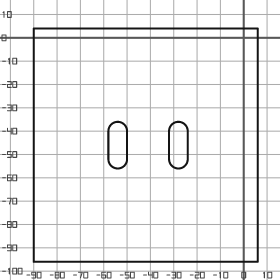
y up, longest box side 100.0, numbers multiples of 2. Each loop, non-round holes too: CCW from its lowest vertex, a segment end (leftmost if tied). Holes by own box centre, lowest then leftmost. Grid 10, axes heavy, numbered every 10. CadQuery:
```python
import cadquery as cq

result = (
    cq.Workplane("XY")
    .moveTo(-90.0, -96.0)
    .lineTo(6.0, -96.0)
    .lineTo(6.0, 4.0)
    .lineTo(-90.0, 4.0)
    .close()
    .moveTo(-58.0, -52.0)
    .threePointArc((-54.0, -56.0), (-50.0, -52.0))
    .lineTo(-50.0, -40.0)
    .threePointArc((-54.0, -36.0), (-58.0, -40.0))
    .close()
    .moveTo(-32.0, -52.0)
    .threePointArc((-28.0, -56.0), (-24.0, -52.0))
    .lineTo(-24.0, -40.0)
    .threePointArc((-28.0, -36.0), (-32.0, -40.0))
    .close()
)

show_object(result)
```